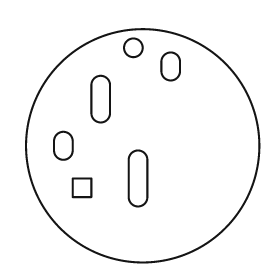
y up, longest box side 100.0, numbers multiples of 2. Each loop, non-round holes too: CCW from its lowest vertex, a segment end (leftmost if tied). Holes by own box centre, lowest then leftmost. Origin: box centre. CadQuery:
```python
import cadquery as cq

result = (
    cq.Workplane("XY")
    .moveTo(0.0, 0.0)
    .circle(50.0)
    .moveTo(-30.0, -22.0)
    .lineTo(-22.0, -22.0)
    .lineTo(-22.0, -14.0)
    .lineTo(-30.0, -14.0)
    .close()
    .moveTo(-6.0, -22.0)
    .threePointArc((-2.0, -26.0), (2.0, -22.0))
    .lineTo(2.0, -6.0)
    .threePointArc((-2.0, -2.0), (-6.0, -6.0))
    .close()
    .moveTo(-38.0, -2.0)
    .threePointArc((-34.0, -6.0), (-30.0, -2.0))
    .lineTo(-30.0, 2.0)
    .threePointArc((-34.0, 6.0), (-38.0, 2.0))
    .close()
    .moveTo(-22.0, 14.0)
    .threePointArc((-18.0, 10.0), (-14.0, 14.0))
    .lineTo(-14.0, 26.0)
    .threePointArc((-18.0, 30.0), (-22.0, 26.0))
    .close()
    .moveTo(8.0, 32.0)
    .threePointArc((12.0, 28.0), (16.0, 32.0))
    .lineTo(16.0, 36.0)
    .threePointArc((12.0, 40.0), (8.0, 36.0))
    .close()
    .moveTo(-4.0, 42.0)
    .circle(4.0)
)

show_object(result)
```